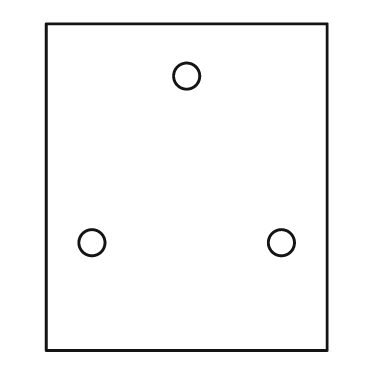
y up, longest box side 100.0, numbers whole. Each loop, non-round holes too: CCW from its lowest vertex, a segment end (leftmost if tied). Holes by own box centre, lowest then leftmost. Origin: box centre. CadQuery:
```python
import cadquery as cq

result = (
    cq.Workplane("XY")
    .moveTo(-43.0, -50.0)
    .lineTo(43.0, -50.0)
    .lineTo(43.0, 50.0)
    .lineTo(-43.0, 50.0)
    .close()
    .moveTo(-29.0, -17.0)
    .circle(4.0)
    .moveTo(29.0, -17.0)
    .circle(4.0)
    .moveTo(0.0, 34.0)
    .circle(4.0)
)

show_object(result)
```